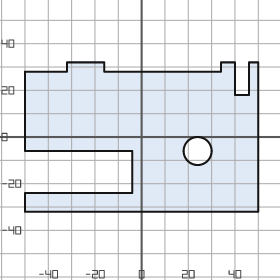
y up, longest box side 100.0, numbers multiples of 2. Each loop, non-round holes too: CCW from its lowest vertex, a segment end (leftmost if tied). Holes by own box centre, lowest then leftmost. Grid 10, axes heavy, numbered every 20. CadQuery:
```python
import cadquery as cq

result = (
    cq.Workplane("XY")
    .moveTo(-50.0, -32.0)
    .lineTo(50.0, -32.0)
    .lineTo(50.0, 32.0)
    .lineTo(46.0, 32.0)
    .lineTo(46.0, 18.0)
    .lineTo(40.0, 18.0)
    .lineTo(40.0, 32.0)
    .lineTo(34.0, 32.0)
    .lineTo(34.0, 28.0)
    .lineTo(-16.0, 28.0)
    .lineTo(-16.0, 32.0)
    .lineTo(-32.0, 32.0)
    .lineTo(-32.0, 28.0)
    .lineTo(-50.0, 28.0)
    .lineTo(-50.0, -6.0)
    .lineTo(-4.0, -6.0)
    .lineTo(-4.0, -24.0)
    .lineTo(-50.0, -24.0)
    .close()
    .moveTo(24.0, -6.0)
    .circle(6.0)
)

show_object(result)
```